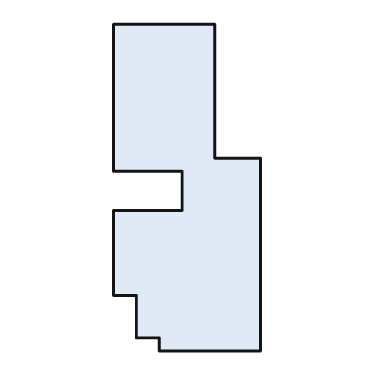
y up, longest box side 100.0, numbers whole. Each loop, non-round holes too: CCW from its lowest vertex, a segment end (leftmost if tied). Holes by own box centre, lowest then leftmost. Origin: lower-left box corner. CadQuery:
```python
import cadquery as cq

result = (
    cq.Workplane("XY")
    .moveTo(14.0, 0.0)
    .lineTo(45.0, 0.0)
    .lineTo(45.0, 59.0)
    .lineTo(31.0, 59.0)
    .lineTo(31.0, 100.0)
    .lineTo(0.0, 100.0)
    .lineTo(0.0, 55.0)
    .lineTo(21.0, 55.0)
    .lineTo(21.0, 43.0)
    .lineTo(0.0, 43.0)
    .lineTo(0.0, 17.0)
    .lineTo(7.0, 17.0)
    .lineTo(7.0, 4.0)
    .lineTo(14.0, 4.0)
    .close()
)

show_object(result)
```